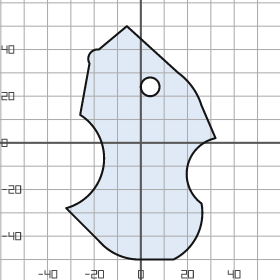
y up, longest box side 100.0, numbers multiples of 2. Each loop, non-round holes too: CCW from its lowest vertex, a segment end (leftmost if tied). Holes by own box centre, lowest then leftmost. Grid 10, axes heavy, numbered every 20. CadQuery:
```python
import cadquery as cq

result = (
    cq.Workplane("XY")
    .moveTo(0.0, -50.0)
    .lineTo(14.0, -50.0)
    .threePointArc((24.0, -40.0), (26.0, -26.0))
    .threePointArc((20.0, -10.0), (32.0, 2.0))
    .lineTo(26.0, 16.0)
    .threePointArc((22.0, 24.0), (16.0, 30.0))
    .lineTo(-6.0, 50.0)
    .lineTo(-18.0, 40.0)
    .threePointArc((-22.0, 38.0), (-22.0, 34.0))
    .lineTo(-26.0, 12.0)
    .threePointArc((-16.0, -10.0), (-32.0, -28.0))
    .lineTo(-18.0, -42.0)
    .threePointArc((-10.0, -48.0), (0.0, -50.0))
    .close()
    .moveTo(4.0, 24.0)
    .circle(4.0)
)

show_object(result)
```